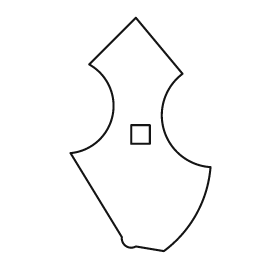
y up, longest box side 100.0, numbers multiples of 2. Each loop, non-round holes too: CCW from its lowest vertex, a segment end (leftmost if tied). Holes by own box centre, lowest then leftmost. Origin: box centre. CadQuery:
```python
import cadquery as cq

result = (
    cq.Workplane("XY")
    .moveTo(10.0, -50.0)
    .threePointArc((24.0, -34.0), (30.0, -14.0))
    .threePointArc((10.0, 2.0), (18.0, 26.0))
    .lineTo(-2.0, 50.0)
    .lineTo(-22.0, 30.0)
    .threePointArc((-12.0, 8.0), (-30.0, -8.0))
    .lineTo(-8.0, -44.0)
    .threePointArc((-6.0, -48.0), (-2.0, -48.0))
    .close()
    .moveTo(-4.0, -4.0)
    .lineTo(4.0, -4.0)
    .lineTo(4.0, 4.0)
    .lineTo(-4.0, 4.0)
    .close()
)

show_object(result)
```